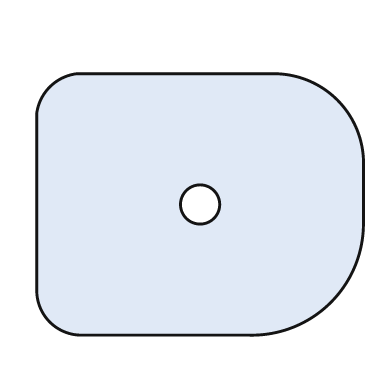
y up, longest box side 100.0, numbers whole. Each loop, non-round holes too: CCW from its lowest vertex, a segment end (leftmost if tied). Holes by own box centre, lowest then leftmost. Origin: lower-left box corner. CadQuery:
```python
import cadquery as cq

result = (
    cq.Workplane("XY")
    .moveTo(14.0, 0.0)
    .lineTo(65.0, 0.0)
    .threePointArc((90.0, 10.0), (100.0, 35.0))
    .lineTo(100.0, 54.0)
    .threePointArc((92.0, 72.0), (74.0, 80.0))
    .lineTo(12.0, 80.0)
    .threePointArc((4.0, 76.0), (0.0, 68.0))
    .lineTo(0.0, 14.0)
    .threePointArc((4.0, 4.0), (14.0, 0.0))
    .close()
    .moveTo(50.0, 40.0)
    .circle(6.0)
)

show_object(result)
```